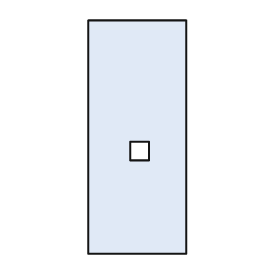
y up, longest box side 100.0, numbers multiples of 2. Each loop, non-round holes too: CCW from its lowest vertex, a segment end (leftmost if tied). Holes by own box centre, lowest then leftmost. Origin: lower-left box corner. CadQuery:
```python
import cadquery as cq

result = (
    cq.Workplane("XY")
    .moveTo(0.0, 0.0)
    .lineTo(42.0, 0.0)
    .lineTo(42.0, 100.0)
    .lineTo(0.0, 100.0)
    .close()
    .moveTo(18.0, 40.0)
    .lineTo(26.0, 40.0)
    .lineTo(26.0, 48.0)
    .lineTo(18.0, 48.0)
    .close()
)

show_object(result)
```